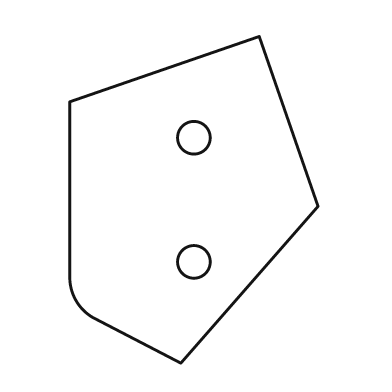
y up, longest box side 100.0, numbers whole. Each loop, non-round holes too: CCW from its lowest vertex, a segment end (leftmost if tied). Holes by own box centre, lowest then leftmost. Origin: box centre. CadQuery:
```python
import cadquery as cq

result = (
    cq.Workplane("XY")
    .moveTo(-4.0, -50.0)
    .lineTo(38.0, -2.0)
    .lineTo(20.0, 50.0)
    .lineTo(-38.0, 30.0)
    .lineTo(-38.0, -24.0)
    .threePointArc((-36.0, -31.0), (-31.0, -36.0))
    .close()
    .moveTo(0.0, -19.0)
    .circle(5.0)
    .moveTo(0.0, 19.0)
    .circle(5.0)
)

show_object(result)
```